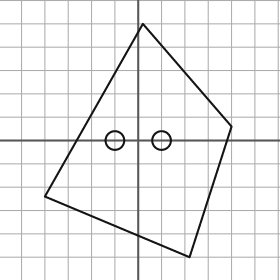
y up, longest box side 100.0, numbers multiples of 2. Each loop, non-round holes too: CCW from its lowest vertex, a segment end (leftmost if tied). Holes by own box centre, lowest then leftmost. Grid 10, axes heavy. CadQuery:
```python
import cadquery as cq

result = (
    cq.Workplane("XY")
    .moveTo(22.0, -50.0)
    .lineTo(40.0, 6.0)
    .lineTo(2.0, 50.0)
    .lineTo(-40.0, -24.0)
    .close()
    .moveTo(-10.0, 0.0)
    .circle(4.0)
    .moveTo(10.0, 0.0)
    .circle(4.0)
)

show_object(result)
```